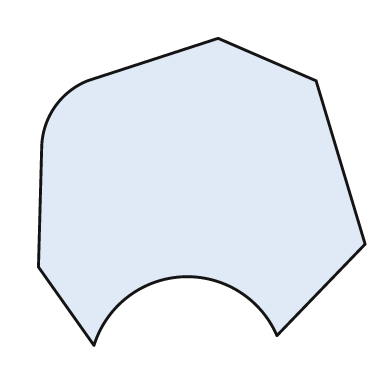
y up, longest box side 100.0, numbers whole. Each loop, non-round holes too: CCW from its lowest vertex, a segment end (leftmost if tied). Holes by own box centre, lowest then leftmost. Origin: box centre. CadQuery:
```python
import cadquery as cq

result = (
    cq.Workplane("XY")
    .moveTo(-33.0, -47.0)
    .threePointArc((-6.0, -26.0), (23.0, -44.0))
    .lineTo(50.0, -16.0)
    .lineTo(35.0, 34.0)
    .lineTo(5.0, 47.0)
    .lineTo(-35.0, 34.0)
    .threePointArc((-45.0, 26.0), (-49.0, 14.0))
    .lineTo(-50.0, -23.0)
    .close()
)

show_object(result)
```